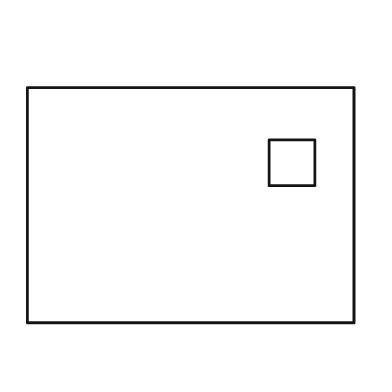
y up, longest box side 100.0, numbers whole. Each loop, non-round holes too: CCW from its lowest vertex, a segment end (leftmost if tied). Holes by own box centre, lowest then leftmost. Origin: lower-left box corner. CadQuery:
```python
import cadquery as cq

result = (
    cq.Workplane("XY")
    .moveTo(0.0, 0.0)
    .lineTo(100.0, 0.0)
    .lineTo(100.0, 72.0)
    .lineTo(0.0, 72.0)
    .close()
    .moveTo(74.0, 42.0)
    .lineTo(88.0, 42.0)
    .lineTo(88.0, 56.0)
    .lineTo(74.0, 56.0)
    .close()
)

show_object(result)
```